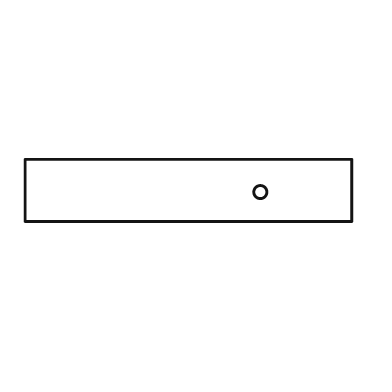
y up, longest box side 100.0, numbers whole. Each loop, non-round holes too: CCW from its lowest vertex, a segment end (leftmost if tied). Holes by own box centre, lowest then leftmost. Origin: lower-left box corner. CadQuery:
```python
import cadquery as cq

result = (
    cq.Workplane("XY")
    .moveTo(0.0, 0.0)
    .lineTo(100.0, 0.0)
    .lineTo(100.0, 19.0)
    .lineTo(0.0, 19.0)
    .close()
    .moveTo(72.0, 9.0)
    .circle(2.0)
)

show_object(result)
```